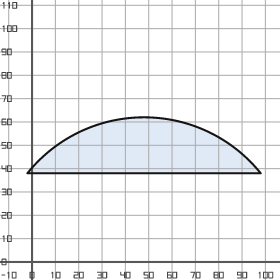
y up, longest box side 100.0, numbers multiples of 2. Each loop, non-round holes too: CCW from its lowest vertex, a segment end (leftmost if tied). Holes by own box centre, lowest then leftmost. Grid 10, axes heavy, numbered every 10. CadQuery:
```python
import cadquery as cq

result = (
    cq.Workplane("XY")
    .moveTo(-2.0, 38.0)
    .lineTo(98.0, 38.0)
    .threePointArc((48.0, 62.0), (-2.0, 38.0))
    .close()
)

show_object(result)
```